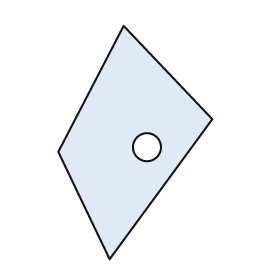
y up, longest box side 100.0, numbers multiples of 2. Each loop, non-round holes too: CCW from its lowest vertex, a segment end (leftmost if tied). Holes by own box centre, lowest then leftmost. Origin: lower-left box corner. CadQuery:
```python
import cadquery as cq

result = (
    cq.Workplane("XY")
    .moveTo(22.0, 0.0)
    .lineTo(66.0, 60.0)
    .lineTo(28.0, 100.0)
    .lineTo(0.0, 46.0)
    .close()
    .moveTo(38.0, 48.0)
    .circle(6.0)
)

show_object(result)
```